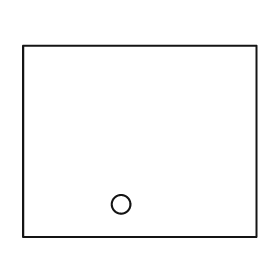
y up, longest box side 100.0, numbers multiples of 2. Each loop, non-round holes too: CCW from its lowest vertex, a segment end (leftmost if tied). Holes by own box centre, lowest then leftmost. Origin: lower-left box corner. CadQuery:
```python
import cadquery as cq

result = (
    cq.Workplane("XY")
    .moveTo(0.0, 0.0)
    .lineTo(100.0, 0.0)
    .lineTo(100.0, 82.0)
    .lineTo(0.0, 82.0)
    .close()
    .moveTo(42.0, 14.0)
    .circle(4.0)
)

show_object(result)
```